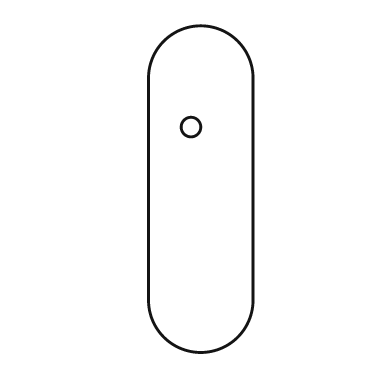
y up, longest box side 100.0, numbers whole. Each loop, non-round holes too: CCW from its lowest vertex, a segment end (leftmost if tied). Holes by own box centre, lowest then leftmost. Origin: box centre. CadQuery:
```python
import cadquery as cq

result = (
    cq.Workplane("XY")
    .moveTo(-16.0, -34.0)
    .threePointArc((0.0, -50.0), (16.0, -34.0))
    .lineTo(16.0, 34.0)
    .threePointArc((0.0, 50.0), (-16.0, 34.0))
    .close()
    .moveTo(-3.0, 19.0)
    .circle(3.0)
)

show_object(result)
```